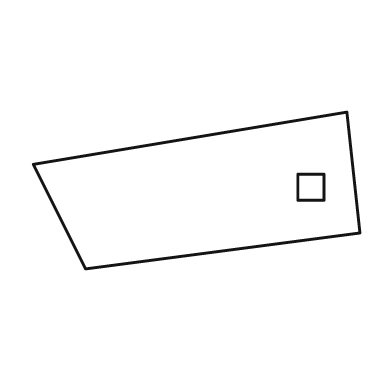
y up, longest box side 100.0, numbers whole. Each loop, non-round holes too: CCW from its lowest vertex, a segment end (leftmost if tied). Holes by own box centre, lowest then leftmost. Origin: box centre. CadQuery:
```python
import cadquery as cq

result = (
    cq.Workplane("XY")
    .moveTo(-34.0, -24.0)
    .lineTo(50.0, -13.0)
    .lineTo(46.0, 24.0)
    .lineTo(-50.0, 8.0)
    .close()
    .moveTo(31.0, -3.0)
    .lineTo(39.0, -3.0)
    .lineTo(39.0, 5.0)
    .lineTo(31.0, 5.0)
    .close()
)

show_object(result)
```